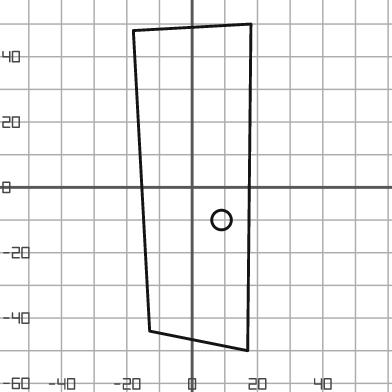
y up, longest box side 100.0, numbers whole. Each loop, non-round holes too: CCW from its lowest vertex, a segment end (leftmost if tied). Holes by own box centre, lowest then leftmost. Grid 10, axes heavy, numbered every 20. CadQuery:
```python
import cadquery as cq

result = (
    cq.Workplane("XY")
    .moveTo(17.0, -50.0)
    .lineTo(18.0, 50.0)
    .lineTo(-18.0, 48.0)
    .lineTo(-13.0, -44.0)
    .close()
    .moveTo(9.0, -10.0)
    .circle(3.0)
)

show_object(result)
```